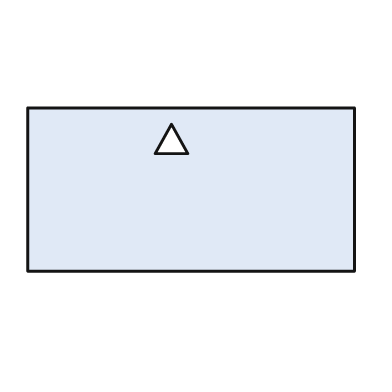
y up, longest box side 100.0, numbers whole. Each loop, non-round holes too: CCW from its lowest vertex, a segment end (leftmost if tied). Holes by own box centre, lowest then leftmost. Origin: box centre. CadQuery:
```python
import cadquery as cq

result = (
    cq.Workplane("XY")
    .moveTo(-50.0, -25.0)
    .lineTo(50.0, -25.0)
    .lineTo(50.0, 25.0)
    .lineTo(-50.0, 25.0)
    .close()
    .moveTo(-11.0, 11.0)
    .lineTo(-1.0, 11.0)
    .lineTo(-6.0, 20.0)
    .close()
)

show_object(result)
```